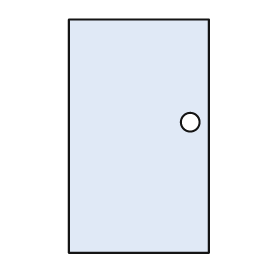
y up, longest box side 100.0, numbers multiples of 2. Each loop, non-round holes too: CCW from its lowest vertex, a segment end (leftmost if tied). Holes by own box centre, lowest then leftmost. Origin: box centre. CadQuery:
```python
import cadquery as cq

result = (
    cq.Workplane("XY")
    .moveTo(-30.0, -50.0)
    .lineTo(30.0, -50.0)
    .lineTo(30.0, 50.0)
    .lineTo(-30.0, 50.0)
    .close()
    .moveTo(22.0, 6.0)
    .circle(4.0)
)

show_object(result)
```